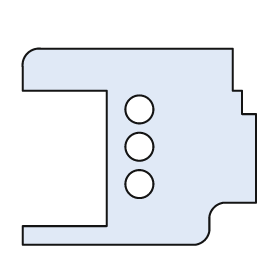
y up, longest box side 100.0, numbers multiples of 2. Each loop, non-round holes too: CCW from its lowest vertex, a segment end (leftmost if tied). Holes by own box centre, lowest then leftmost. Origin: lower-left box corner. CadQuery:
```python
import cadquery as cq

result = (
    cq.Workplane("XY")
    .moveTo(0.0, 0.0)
    .lineTo(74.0, 0.0)
    .threePointArc((78.0, 2.0), (80.0, 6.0))
    .lineTo(80.0, 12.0)
    .threePointArc((82.0, 16.0), (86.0, 18.0))
    .lineTo(100.0, 18.0)
    .lineTo(100.0, 56.0)
    .lineTo(94.0, 56.0)
    .lineTo(94.0, 66.0)
    .lineTo(90.0, 66.0)
    .lineTo(90.0, 84.0)
    .lineTo(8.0, 84.0)
    .threePointArc((2.0, 82.0), (0.0, 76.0))
    .lineTo(0.0, 66.0)
    .lineTo(36.0, 66.0)
    .lineTo(36.0, 8.0)
    .lineTo(0.0, 8.0)
    .close()
    .moveTo(50.0, 26.0)
    .circle(6.0)
    .moveTo(50.0, 42.0)
    .circle(6.0)
    .moveTo(50.0, 58.0)
    .circle(6.0)
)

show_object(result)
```